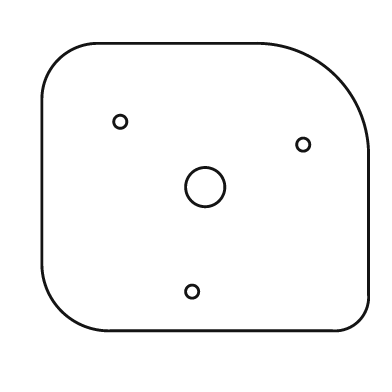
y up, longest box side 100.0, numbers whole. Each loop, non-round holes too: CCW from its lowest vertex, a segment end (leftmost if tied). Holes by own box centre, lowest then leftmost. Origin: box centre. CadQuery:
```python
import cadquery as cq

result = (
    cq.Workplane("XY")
    .moveTo(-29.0, -44.0)
    .lineTo(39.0, -44.0)
    .threePointArc((47.0, -41.0), (50.0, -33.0))
    .lineTo(50.0, 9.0)
    .threePointArc((40.0, 34.0), (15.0, 44.0))
    .lineTo(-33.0, 44.0)
    .threePointArc((-45.0, 39.0), (-50.0, 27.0))
    .lineTo(-50.0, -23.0)
    .threePointArc((-44.0, -38.0), (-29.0, -44.0))
    .close()
    .moveTo(-4.0, -32.0)
    .circle(2.0)
    .moveTo(0.0, 0.0)
    .circle(6.0)
    .moveTo(30.0, 13.0)
    .circle(2.0)
    .moveTo(-26.0, 20.0)
    .circle(2.0)
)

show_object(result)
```